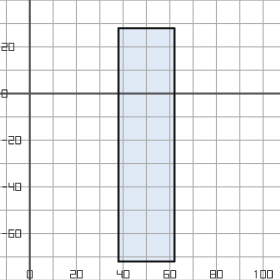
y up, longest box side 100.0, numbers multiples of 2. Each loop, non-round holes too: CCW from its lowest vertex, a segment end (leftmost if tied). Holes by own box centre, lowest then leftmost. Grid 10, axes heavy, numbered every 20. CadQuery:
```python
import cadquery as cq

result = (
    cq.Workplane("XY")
    .moveTo(38.0, -72.0)
    .lineTo(62.0, -72.0)
    .lineTo(62.0, 28.0)
    .lineTo(38.0, 28.0)
    .close()
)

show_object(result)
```